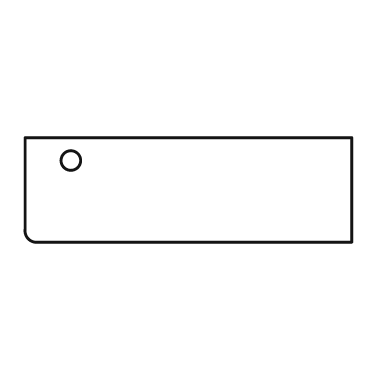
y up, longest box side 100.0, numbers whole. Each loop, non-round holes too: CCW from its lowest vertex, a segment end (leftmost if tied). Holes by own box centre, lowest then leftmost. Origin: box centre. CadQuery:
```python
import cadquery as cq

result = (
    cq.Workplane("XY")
    .moveTo(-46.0, -16.0)
    .lineTo(50.0, -16.0)
    .lineTo(50.0, 16.0)
    .lineTo(-50.0, 16.0)
    .lineTo(-50.0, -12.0)
    .threePointArc((-49.0, -15.0), (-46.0, -16.0))
    .close()
    .moveTo(-36.0, 9.0)
    .circle(3.0)
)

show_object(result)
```